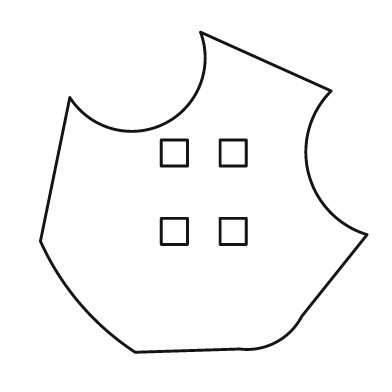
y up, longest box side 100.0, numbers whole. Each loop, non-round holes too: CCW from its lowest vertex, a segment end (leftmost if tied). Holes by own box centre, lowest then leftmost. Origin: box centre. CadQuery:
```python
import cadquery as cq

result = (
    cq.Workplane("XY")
    .moveTo(-21.0, -49.0)
    .lineTo(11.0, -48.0)
    .threePointArc((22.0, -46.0), (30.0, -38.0))
    .lineTo(50.0, -13.0)
    .threePointArc((32.0, 6.0), (39.0, 31.0))
    .lineTo(-1.0, 49.0)
    .threePointArc((-12.0, 21.0), (-41.0, 29.0))
    .lineTo(-50.0, -15.0)
    .threePointArc((-38.0, -34.0), (-21.0, -49.0))
    .close()
    .moveTo(-13.0, -16.0)
    .lineTo(-5.0, -16.0)
    .lineTo(-5.0, -8.0)
    .lineTo(-13.0, -8.0)
    .close()
    .moveTo(5.0, -16.0)
    .lineTo(13.0, -16.0)
    .lineTo(13.0, -8.0)
    .lineTo(5.0, -8.0)
    .close()
    .moveTo(-13.0, 8.0)
    .lineTo(-5.0, 8.0)
    .lineTo(-5.0, 16.0)
    .lineTo(-13.0, 16.0)
    .close()
    .moveTo(5.0, 8.0)
    .lineTo(13.0, 8.0)
    .lineTo(13.0, 16.0)
    .lineTo(5.0, 16.0)
    .close()
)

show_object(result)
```